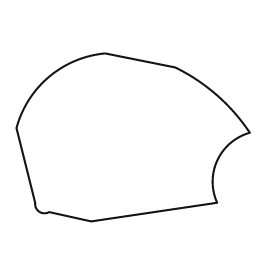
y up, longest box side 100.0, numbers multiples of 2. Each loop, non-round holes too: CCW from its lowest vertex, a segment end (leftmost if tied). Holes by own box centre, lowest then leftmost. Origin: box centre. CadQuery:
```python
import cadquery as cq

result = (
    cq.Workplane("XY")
    .moveTo(-18.0, -36.0)
    .lineTo(36.0, -28.0)
    .threePointArc((36.0, -10.0), (50.0, 2.0))
    .threePointArc((36.0, 18.0), (18.0, 30.0))
    .lineTo(-12.0, 36.0)
    .threePointArc((-36.0, 26.0), (-50.0, 4.0))
    .lineTo(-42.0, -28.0)
    .threePointArc((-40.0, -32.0), (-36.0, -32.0))
    .close()
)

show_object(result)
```